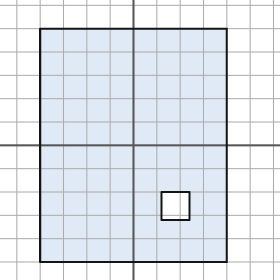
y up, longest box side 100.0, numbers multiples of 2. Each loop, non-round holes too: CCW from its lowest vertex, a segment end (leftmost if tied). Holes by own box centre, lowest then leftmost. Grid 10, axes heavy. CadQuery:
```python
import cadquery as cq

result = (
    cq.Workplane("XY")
    .moveTo(-40.0, -50.0)
    .lineTo(40.0, -50.0)
    .lineTo(40.0, 50.0)
    .lineTo(-40.0, 50.0)
    .close()
    .moveTo(12.0, -32.0)
    .lineTo(24.0, -32.0)
    .lineTo(24.0, -20.0)
    .lineTo(12.0, -20.0)
    .close()
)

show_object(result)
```